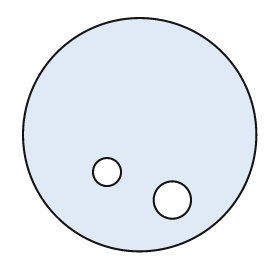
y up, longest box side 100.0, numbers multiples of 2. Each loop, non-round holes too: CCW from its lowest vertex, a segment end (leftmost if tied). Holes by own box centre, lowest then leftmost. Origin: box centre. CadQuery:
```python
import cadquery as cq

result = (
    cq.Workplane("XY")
    .moveTo(0.0, 0.0)
    .circle(50.0)
    .moveTo(14.0, -28.0)
    .circle(8.0)
    .moveTo(-14.0, -16.0)
    .circle(6.0)
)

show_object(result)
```